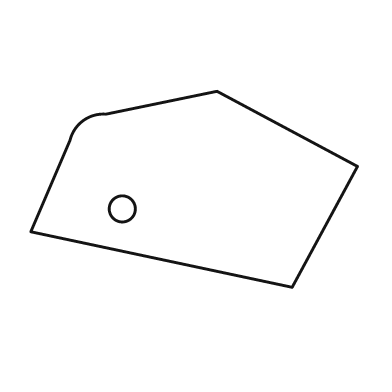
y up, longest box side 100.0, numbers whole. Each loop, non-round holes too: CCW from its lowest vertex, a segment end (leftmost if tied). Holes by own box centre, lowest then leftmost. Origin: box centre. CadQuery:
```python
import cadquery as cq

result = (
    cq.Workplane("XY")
    .moveTo(30.0, -30.0)
    .lineTo(50.0, 7.0)
    .lineTo(7.0, 30.0)
    .lineTo(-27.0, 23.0)
    .threePointArc((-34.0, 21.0), (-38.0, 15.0))
    .lineTo(-50.0, -13.0)
    .close()
    .moveTo(-22.0, -6.0)
    .circle(4.0)
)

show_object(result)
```